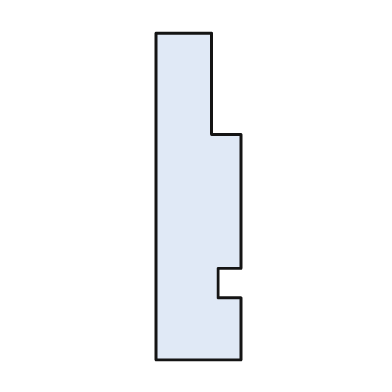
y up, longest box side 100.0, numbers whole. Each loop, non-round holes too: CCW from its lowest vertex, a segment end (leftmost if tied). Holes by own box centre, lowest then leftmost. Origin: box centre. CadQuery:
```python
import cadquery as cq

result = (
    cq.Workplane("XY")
    .moveTo(-13.0, -50.0)
    .lineTo(13.0, -50.0)
    .lineTo(13.0, -31.0)
    .lineTo(6.0, -31.0)
    .lineTo(6.0, -22.0)
    .lineTo(13.0, -22.0)
    .lineTo(13.0, 19.0)
    .lineTo(4.0, 19.0)
    .lineTo(4.0, 50.0)
    .lineTo(-13.0, 50.0)
    .close()
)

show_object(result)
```